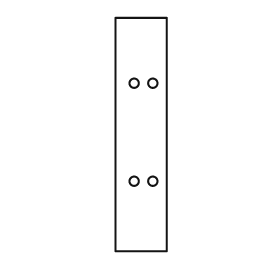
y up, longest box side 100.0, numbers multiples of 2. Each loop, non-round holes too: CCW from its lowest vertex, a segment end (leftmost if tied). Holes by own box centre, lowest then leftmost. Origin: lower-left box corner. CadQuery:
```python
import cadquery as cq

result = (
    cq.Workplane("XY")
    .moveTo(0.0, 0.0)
    .lineTo(22.0, 0.0)
    .lineTo(22.0, 100.0)
    .lineTo(0.0, 100.0)
    .close()
    .moveTo(8.0, 30.0)
    .circle(2.0)
    .moveTo(16.0, 30.0)
    .circle(2.0)
    .moveTo(8.0, 72.0)
    .circle(2.0)
    .moveTo(16.0, 72.0)
    .circle(2.0)
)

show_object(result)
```